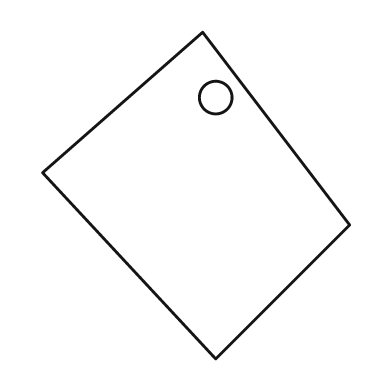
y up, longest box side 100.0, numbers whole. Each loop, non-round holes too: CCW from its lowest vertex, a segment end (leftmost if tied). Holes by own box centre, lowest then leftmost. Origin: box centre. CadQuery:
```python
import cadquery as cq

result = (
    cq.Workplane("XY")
    .moveTo(6.0, -50.0)
    .lineTo(47.0, -9.0)
    .lineTo(2.0, 50.0)
    .lineTo(-47.0, 7.0)
    .close()
    .moveTo(6.0, 30.0)
    .circle(5.0)
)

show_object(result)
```